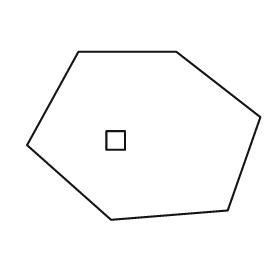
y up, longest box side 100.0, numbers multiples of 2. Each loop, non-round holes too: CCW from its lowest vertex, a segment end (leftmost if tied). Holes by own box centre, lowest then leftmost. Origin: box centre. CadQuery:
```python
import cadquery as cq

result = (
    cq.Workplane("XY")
    .moveTo(-14.0, -36.0)
    .lineTo(36.0, -32.0)
    .lineTo(50.0, 8.0)
    .lineTo(14.0, 36.0)
    .lineTo(-28.0, 36.0)
    .lineTo(-50.0, -4.0)
    .close()
    .moveTo(-16.0, -6.0)
    .lineTo(-8.0, -6.0)
    .lineTo(-8.0, 2.0)
    .lineTo(-16.0, 2.0)
    .close()
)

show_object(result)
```